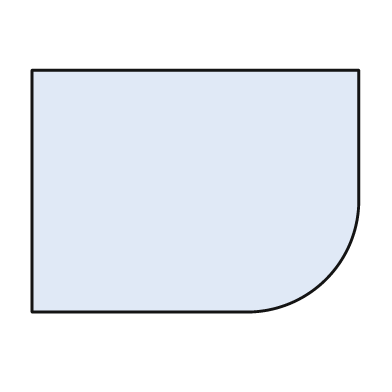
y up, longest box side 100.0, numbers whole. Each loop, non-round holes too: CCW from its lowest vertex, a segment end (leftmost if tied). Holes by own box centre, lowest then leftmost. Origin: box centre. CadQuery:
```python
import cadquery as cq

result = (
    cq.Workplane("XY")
    .moveTo(-50.0, -37.0)
    .lineTo(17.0, -37.0)
    .threePointArc((40.0, -27.0), (50.0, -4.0))
    .lineTo(50.0, 37.0)
    .lineTo(-50.0, 37.0)
    .close()
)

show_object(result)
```